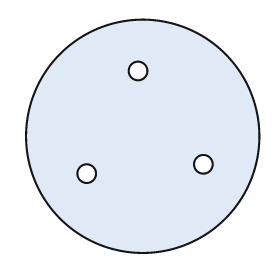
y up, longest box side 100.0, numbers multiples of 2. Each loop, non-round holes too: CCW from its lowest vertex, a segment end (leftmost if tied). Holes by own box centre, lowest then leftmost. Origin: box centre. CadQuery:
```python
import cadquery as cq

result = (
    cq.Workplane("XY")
    .moveTo(0.0, 0.0)
    .circle(50.0)
    .moveTo(-24.0, -16.0)
    .circle(4.0)
    .moveTo(26.0, -12.0)
    .circle(4.0)
    .moveTo(-2.0, 28.0)
    .circle(4.0)
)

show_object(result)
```